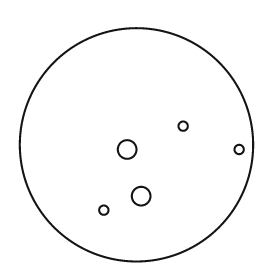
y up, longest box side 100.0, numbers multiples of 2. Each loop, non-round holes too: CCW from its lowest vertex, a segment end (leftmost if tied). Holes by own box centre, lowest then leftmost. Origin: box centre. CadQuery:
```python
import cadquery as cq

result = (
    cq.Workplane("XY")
    .moveTo(0.0, 0.0)
    .circle(50.0)
    .moveTo(-14.0, -28.0)
    .circle(2.0)
    .moveTo(2.0, -22.0)
    .circle(4.0)
    .moveTo(-4.0, -2.0)
    .circle(4.0)
    .moveTo(44.0, -2.0)
    .circle(2.0)
    .moveTo(20.0, 8.0)
    .circle(2.0)
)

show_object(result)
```